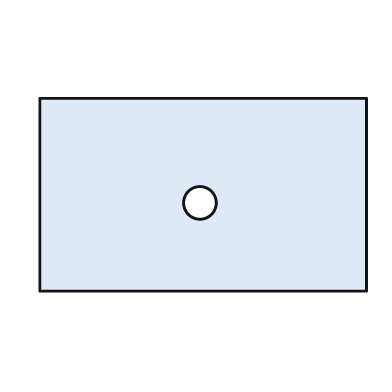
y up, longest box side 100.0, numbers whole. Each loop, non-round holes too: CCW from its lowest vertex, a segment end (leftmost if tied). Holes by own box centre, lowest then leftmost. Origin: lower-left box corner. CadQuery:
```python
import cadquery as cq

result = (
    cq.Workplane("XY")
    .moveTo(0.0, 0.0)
    .lineTo(100.0, 0.0)
    .lineTo(100.0, 59.0)
    .lineTo(0.0, 59.0)
    .close()
    .moveTo(49.0, 27.0)
    .circle(5.0)
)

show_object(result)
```